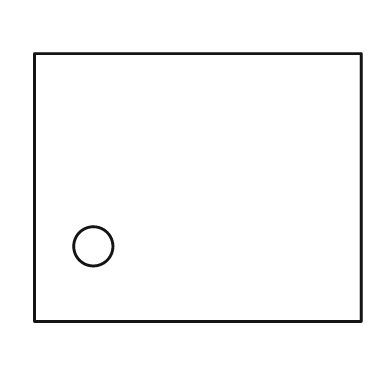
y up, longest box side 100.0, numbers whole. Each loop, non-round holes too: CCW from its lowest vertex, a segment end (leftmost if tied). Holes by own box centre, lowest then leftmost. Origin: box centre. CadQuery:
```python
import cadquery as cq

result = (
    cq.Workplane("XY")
    .moveTo(-50.0, -41.0)
    .lineTo(50.0, -41.0)
    .lineTo(50.0, 41.0)
    .lineTo(-50.0, 41.0)
    .close()
    .moveTo(-32.0, -18.0)
    .circle(6.0)
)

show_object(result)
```